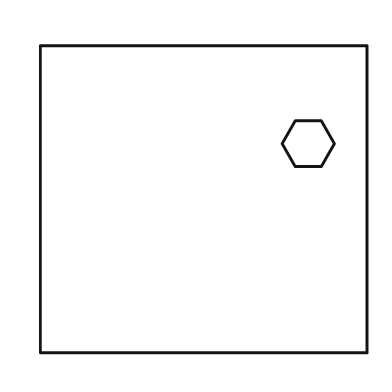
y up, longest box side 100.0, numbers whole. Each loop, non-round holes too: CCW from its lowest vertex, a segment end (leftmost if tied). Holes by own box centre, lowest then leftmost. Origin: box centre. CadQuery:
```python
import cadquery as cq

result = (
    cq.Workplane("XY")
    .moveTo(-50.0, -47.0)
    .lineTo(50.0, -47.0)
    .lineTo(50.0, 47.0)
    .lineTo(-50.0, 47.0)
    .close()
    .moveTo(28.0, 10.0)
    .lineTo(36.0, 10.0)
    .lineTo(40.0, 17.0)
    .lineTo(36.0, 24.0)
    .lineTo(28.0, 24.0)
    .lineTo(24.0, 17.0)
    .close()
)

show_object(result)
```